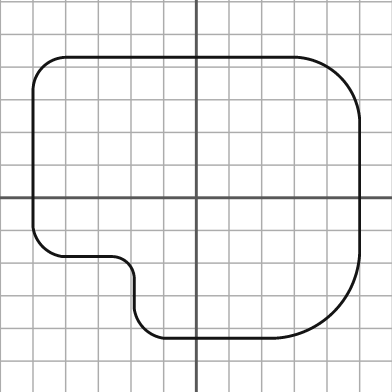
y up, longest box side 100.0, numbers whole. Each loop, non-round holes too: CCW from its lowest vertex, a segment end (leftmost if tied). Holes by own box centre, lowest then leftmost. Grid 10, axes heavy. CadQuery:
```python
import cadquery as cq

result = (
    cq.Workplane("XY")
    .moveTo(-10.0, -43.0)
    .lineTo(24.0, -43.0)
    .threePointArc((42.0, -35.0), (50.0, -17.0))
    .lineTo(50.0, 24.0)
    .threePointArc((44.0, 37.0), (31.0, 43.0))
    .lineTo(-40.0, 43.0)
    .threePointArc((-47.0, 40.0), (-50.0, 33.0))
    .lineTo(-50.0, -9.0)
    .threePointArc((-47.0, -15.0), (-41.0, -18.0))
    .lineTo(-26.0, -18.0)
    .threePointArc((-21.0, -20.0), (-19.0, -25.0))
    .lineTo(-19.0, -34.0)
    .threePointArc((-16.0, -40.0), (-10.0, -43.0))
    .close()
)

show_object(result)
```